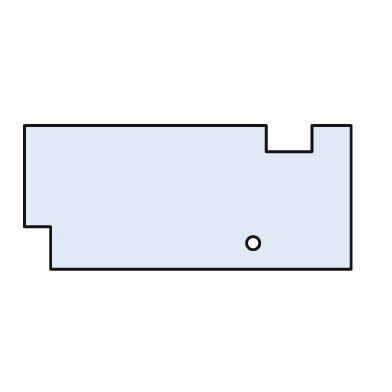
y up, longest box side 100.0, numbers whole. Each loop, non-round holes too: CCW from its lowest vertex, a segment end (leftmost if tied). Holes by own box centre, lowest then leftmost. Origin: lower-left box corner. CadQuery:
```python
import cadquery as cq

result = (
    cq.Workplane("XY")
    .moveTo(8.0, 0.0)
    .lineTo(100.0, 0.0)
    .lineTo(100.0, 44.0)
    .lineTo(88.0, 44.0)
    .lineTo(88.0, 36.0)
    .lineTo(74.0, 36.0)
    .lineTo(74.0, 44.0)
    .lineTo(0.0, 44.0)
    .lineTo(0.0, 13.0)
    .lineTo(8.0, 13.0)
    .close()
    .moveTo(70.0, 8.0)
    .circle(2.0)
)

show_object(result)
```